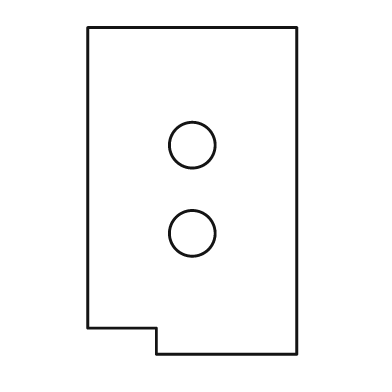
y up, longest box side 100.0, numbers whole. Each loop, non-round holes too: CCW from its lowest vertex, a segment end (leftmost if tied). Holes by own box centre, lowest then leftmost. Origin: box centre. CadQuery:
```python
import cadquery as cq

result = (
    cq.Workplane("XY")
    .moveTo(-11.0, -50.0)
    .lineTo(32.0, -50.0)
    .lineTo(32.0, 50.0)
    .lineTo(-32.0, 50.0)
    .lineTo(-32.0, -42.0)
    .lineTo(-11.0, -42.0)
    .close()
    .moveTo(0.0, -13.0)
    .circle(7.0)
    .moveTo(0.0, 14.0)
    .circle(7.0)
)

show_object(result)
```